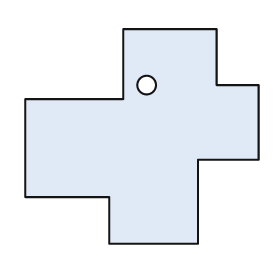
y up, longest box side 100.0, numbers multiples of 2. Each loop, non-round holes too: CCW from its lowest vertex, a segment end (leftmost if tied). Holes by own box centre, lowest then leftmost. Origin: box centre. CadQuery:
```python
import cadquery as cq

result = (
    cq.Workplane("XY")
    .moveTo(-14.0, -46.0)
    .lineTo(24.0, -46.0)
    .lineTo(24.0, -10.0)
    .lineTo(50.0, -10.0)
    .lineTo(50.0, 22.0)
    .lineTo(32.0, 22.0)
    .lineTo(32.0, 46.0)
    .lineTo(-8.0, 46.0)
    .lineTo(-8.0, 16.0)
    .lineTo(-50.0, 16.0)
    .lineTo(-50.0, -26.0)
    .lineTo(-14.0, -26.0)
    .close()
    .moveTo(2.0, 22.0)
    .circle(4.0)
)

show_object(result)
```